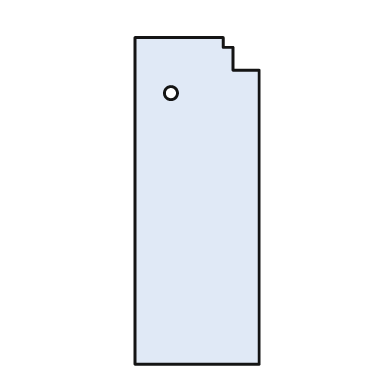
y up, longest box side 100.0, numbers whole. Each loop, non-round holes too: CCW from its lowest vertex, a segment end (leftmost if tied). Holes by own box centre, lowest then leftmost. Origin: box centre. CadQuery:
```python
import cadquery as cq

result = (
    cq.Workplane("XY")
    .moveTo(-19.0, -50.0)
    .lineTo(19.0, -50.0)
    .lineTo(19.0, 40.0)
    .lineTo(11.0, 40.0)
    .lineTo(11.0, 47.0)
    .lineTo(8.0, 47.0)
    .lineTo(8.0, 50.0)
    .lineTo(-19.0, 50.0)
    .close()
    .moveTo(-8.0, 33.0)
    .circle(2.0)
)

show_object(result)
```